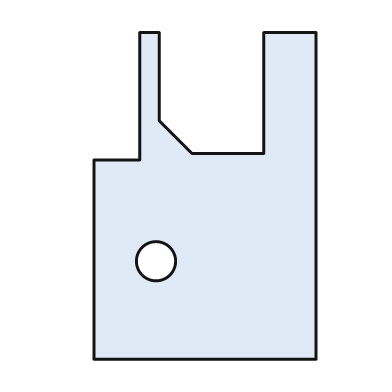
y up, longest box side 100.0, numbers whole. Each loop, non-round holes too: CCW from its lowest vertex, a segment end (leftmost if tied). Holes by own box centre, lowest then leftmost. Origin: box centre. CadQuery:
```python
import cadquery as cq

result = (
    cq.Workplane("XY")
    .moveTo(-34.0, -50.0)
    .lineTo(34.0, -50.0)
    .lineTo(34.0, 50.0)
    .lineTo(18.0, 50.0)
    .lineTo(18.0, 13.0)
    .lineTo(-4.0, 13.0)
    .lineTo(-14.0, 23.0)
    .lineTo(-14.0, 50.0)
    .lineTo(-20.0, 50.0)
    .lineTo(-20.0, 11.0)
    .lineTo(-34.0, 11.0)
    .close()
    .moveTo(-15.0, -20.0)
    .circle(6.0)
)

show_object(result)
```